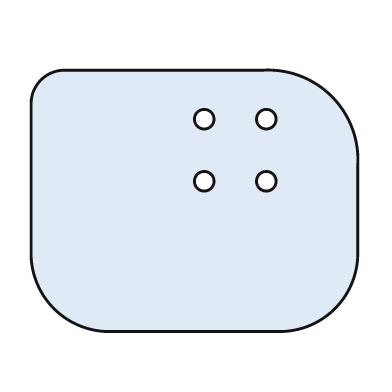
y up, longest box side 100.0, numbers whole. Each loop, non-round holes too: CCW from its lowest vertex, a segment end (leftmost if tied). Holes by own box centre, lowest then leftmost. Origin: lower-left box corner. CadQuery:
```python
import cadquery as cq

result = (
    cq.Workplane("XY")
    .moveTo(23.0, 0.0)
    .lineTo(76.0, 0.0)
    .threePointArc((93.0, 7.0), (100.0, 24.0))
    .lineTo(100.0, 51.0)
    .threePointArc((92.0, 72.0), (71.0, 80.0))
    .lineTo(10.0, 80.0)
    .threePointArc((3.0, 77.0), (0.0, 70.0))
    .lineTo(0.0, 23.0)
    .threePointArc((7.0, 7.0), (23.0, 0.0))
    .close()
    .moveTo(53.0, 46.0)
    .circle(3.0)
    .moveTo(72.0, 46.0)
    .circle(3.0)
    .moveTo(53.0, 65.0)
    .circle(3.0)
    .moveTo(72.0, 65.0)
    .circle(3.0)
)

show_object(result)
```